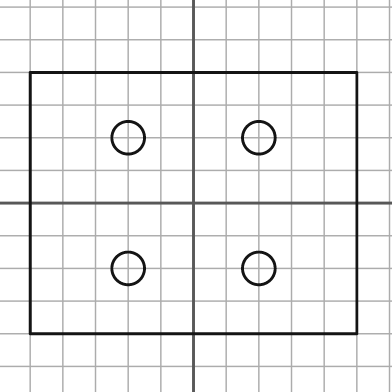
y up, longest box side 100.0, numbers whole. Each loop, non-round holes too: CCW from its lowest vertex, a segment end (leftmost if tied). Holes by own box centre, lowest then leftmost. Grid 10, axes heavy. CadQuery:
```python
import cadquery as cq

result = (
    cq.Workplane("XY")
    .moveTo(-50.0, -40.0)
    .lineTo(50.0, -40.0)
    .lineTo(50.0, 40.0)
    .lineTo(-50.0, 40.0)
    .close()
    .moveTo(-20.0, -20.0)
    .circle(5.0)
    .moveTo(20.0, -20.0)
    .circle(5.0)
    .moveTo(-20.0, 20.0)
    .circle(5.0)
    .moveTo(20.0, 20.0)
    .circle(5.0)
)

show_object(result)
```